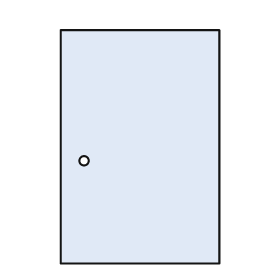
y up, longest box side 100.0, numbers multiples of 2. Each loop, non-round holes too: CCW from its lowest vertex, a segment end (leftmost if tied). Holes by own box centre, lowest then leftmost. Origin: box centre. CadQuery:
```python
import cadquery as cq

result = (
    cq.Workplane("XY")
    .moveTo(-34.0, -50.0)
    .lineTo(34.0, -50.0)
    .lineTo(34.0, 50.0)
    .lineTo(-34.0, 50.0)
    .close()
    .moveTo(-24.0, -6.0)
    .circle(2.0)
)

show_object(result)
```